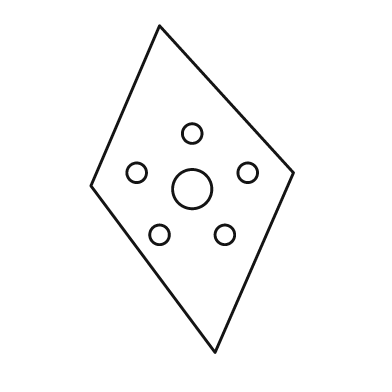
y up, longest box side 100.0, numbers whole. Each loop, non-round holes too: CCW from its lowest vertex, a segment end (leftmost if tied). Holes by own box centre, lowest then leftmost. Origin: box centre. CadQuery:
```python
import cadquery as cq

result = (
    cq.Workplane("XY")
    .moveTo(7.0, -50.0)
    .lineTo(31.0, 5.0)
    .lineTo(-10.0, 50.0)
    .lineTo(-31.0, 1.0)
    .close()
    .moveTo(-10.0, -14.0)
    .circle(3.0)
    .moveTo(10.0, -14.0)
    .circle(3.0)
    .moveTo(0.0, 0.0)
    .circle(6.0)
    .moveTo(-17.0, 5.0)
    .circle(3.0)
    .moveTo(17.0, 5.0)
    .circle(3.0)
    .moveTo(0.0, 17.0)
    .circle(3.0)
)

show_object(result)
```